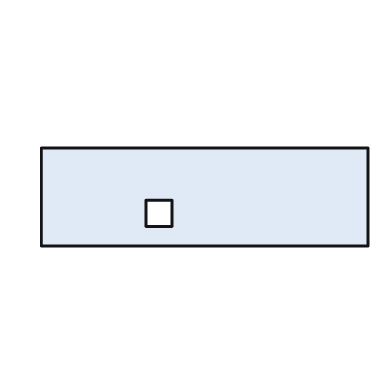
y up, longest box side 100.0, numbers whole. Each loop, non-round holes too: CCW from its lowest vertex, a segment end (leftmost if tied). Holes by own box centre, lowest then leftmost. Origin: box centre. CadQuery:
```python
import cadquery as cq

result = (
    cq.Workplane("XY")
    .moveTo(-50.0, -15.0)
    .lineTo(50.0, -15.0)
    .lineTo(50.0, 15.0)
    .lineTo(-50.0, 15.0)
    .close()
    .moveTo(-18.0, -9.0)
    .lineTo(-10.0, -9.0)
    .lineTo(-10.0, -1.0)
    .lineTo(-18.0, -1.0)
    .close()
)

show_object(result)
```